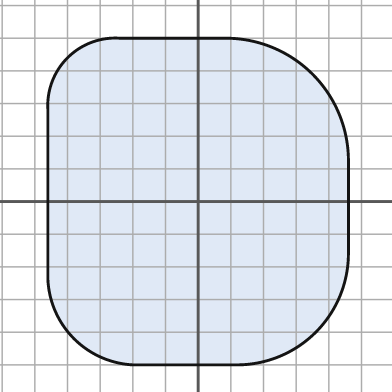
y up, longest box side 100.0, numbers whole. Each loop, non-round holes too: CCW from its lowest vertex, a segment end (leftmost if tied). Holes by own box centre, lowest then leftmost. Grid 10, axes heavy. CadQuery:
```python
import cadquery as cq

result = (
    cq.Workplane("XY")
    .moveTo(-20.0, -50.0)
    .lineTo(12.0, -50.0)
    .threePointArc((36.0, -40.0), (46.0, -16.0))
    .lineTo(46.0, 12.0)
    .threePointArc((35.0, 39.0), (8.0, 50.0))
    .lineTo(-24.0, 50.0)
    .threePointArc((-40.0, 44.0), (-46.0, 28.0))
    .lineTo(-46.0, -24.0)
    .threePointArc((-38.0, -42.0), (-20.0, -50.0))
    .close()
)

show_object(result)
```